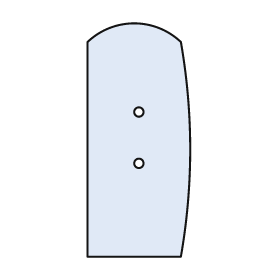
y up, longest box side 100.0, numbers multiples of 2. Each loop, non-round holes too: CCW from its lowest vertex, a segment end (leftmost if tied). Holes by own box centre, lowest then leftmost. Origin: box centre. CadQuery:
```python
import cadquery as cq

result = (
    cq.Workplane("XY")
    .moveTo(-22.0, -50.0)
    .lineTo(18.0, -50.0)
    .threePointArc((22.0, -4.0), (18.0, 42.0))
    .threePointArc((-2.0, 50.0), (-22.0, 42.0))
    .close()
    .moveTo(0.0, -10.0)
    .circle(2.0)
    .moveTo(0.0, 12.0)
    .circle(2.0)
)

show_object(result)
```